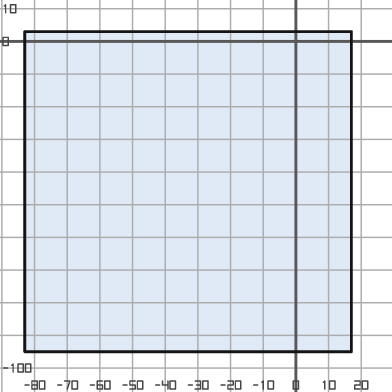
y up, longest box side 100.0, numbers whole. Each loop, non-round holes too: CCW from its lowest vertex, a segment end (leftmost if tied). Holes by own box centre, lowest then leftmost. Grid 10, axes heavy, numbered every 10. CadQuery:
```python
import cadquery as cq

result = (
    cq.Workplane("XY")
    .moveTo(-83.0, -95.0)
    .lineTo(17.0, -95.0)
    .lineTo(17.0, 3.0)
    .lineTo(-83.0, 3.0)
    .close()
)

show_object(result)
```